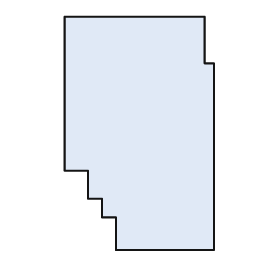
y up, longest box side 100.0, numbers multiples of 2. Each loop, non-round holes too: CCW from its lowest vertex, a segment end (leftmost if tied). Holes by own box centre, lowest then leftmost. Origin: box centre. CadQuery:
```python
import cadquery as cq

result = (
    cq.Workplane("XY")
    .moveTo(-10.0, -50.0)
    .lineTo(32.0, -50.0)
    .lineTo(32.0, 30.0)
    .lineTo(28.0, 30.0)
    .lineTo(28.0, 50.0)
    .lineTo(-32.0, 50.0)
    .lineTo(-32.0, -16.0)
    .lineTo(-22.0, -16.0)
    .lineTo(-22.0, -28.0)
    .lineTo(-16.0, -28.0)
    .lineTo(-16.0, -36.0)
    .lineTo(-10.0, -36.0)
    .close()
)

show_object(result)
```